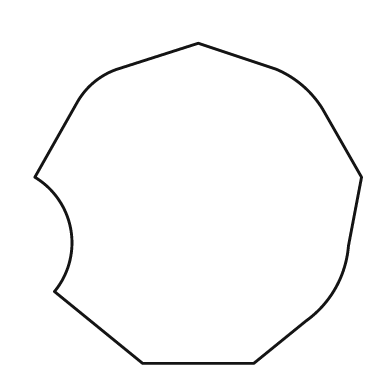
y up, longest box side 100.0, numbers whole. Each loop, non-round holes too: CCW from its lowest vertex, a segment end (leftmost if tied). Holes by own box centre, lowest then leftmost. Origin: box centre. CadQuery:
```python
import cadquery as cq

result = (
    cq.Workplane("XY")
    .moveTo(-17.0, -49.0)
    .lineTo(17.0, -49.0)
    .lineTo(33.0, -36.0)
    .threePointArc((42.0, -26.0), (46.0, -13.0))
    .lineTo(50.0, 8.0)
    .lineTo(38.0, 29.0)
    .threePointArc((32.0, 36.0), (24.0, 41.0))
    .lineTo(0.0, 49.0)
    .lineTo(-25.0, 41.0)
    .threePointArc((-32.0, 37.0), (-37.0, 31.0))
    .lineTo(-50.0, 8.0)
    .threePointArc((-39.0, -8.0), (-44.0, -27.0))
    .close()
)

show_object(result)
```